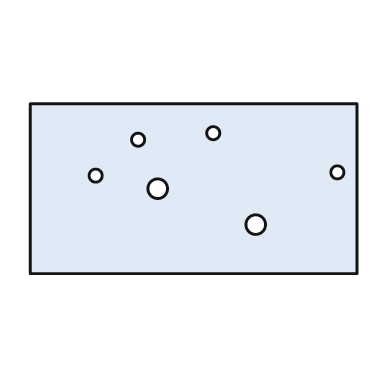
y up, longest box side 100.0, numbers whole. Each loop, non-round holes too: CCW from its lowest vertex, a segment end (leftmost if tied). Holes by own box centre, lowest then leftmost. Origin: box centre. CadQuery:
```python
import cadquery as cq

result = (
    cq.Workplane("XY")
    .moveTo(-50.0, -26.0)
    .lineTo(50.0, -26.0)
    .lineTo(50.0, 26.0)
    .lineTo(-50.0, 26.0)
    .close()
    .moveTo(19.0, -11.0)
    .circle(3.0)
    .moveTo(-11.0, 0.0)
    .circle(3.0)
    .moveTo(-30.0, 4.0)
    .circle(2.0)
    .moveTo(44.0, 5.0)
    .circle(2.0)
    .moveTo(-17.0, 15.0)
    .circle(2.0)
    .moveTo(6.0, 17.0)
    .circle(2.0)
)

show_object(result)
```